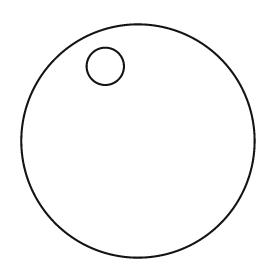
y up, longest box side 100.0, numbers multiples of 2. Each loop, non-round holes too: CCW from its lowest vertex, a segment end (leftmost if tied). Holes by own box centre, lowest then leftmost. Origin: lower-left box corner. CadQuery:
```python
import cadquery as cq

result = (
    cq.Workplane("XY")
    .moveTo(50.0, 50.0)
    .circle(50.0)
    .moveTo(36.0, 82.0)
    .circle(8.0)
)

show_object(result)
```